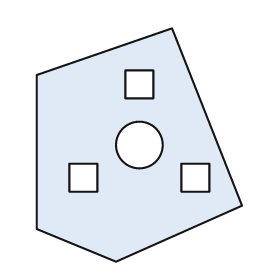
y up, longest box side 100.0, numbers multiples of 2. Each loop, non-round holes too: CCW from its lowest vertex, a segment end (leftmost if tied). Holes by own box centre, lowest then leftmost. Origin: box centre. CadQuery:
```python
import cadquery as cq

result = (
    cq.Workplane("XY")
    .moveTo(-10.0, -50.0)
    .lineTo(44.0, -26.0)
    .lineTo(14.0, 50.0)
    .lineTo(-44.0, 30.0)
    .lineTo(-44.0, -36.0)
    .close()
    .moveTo(-30.0, -20.0)
    .lineTo(-18.0, -20.0)
    .lineTo(-18.0, -8.0)
    .lineTo(-30.0, -8.0)
    .close()
    .moveTo(18.0, -20.0)
    .lineTo(30.0, -20.0)
    .lineTo(30.0, -8.0)
    .lineTo(18.0, -8.0)
    .close()
    .moveTo(0.0, 0.0)
    .circle(10.0)
    .moveTo(-6.0, 20.0)
    .lineTo(6.0, 20.0)
    .lineTo(6.0, 32.0)
    .lineTo(-6.0, 32.0)
    .close()
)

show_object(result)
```